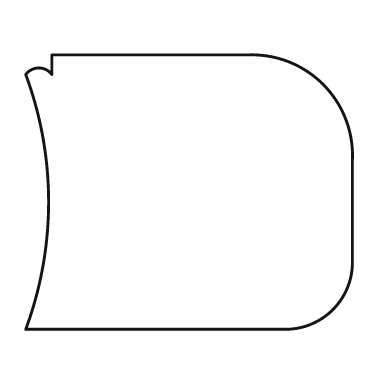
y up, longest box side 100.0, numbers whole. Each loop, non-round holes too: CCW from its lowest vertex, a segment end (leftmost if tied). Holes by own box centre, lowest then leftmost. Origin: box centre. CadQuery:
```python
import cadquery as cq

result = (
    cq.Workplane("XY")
    .moveTo(-50.0, -42.0)
    .lineTo(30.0, -42.0)
    .threePointArc((44.0, -36.0), (50.0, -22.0))
    .lineTo(50.0, 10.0)
    .threePointArc((41.0, 33.0), (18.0, 42.0))
    .lineTo(-42.0, 42.0)
    .lineTo(-42.0, 36.0)
    .threePointArc((-46.0, 38.0), (-50.0, 36.0))
    .threePointArc((-43.0, -3.0), (-50.0, -42.0))
    .close()
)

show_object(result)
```